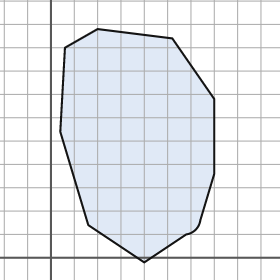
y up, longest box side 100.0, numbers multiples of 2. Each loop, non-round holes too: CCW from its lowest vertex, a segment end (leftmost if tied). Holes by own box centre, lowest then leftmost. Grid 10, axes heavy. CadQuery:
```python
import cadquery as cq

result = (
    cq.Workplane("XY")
    .moveTo(40.0, -2.0)
    .lineTo(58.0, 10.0)
    .threePointArc((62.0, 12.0), (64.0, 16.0))
    .lineTo(70.0, 36.0)
    .lineTo(70.0, 68.0)
    .lineTo(52.0, 94.0)
    .lineTo(20.0, 98.0)
    .lineTo(6.0, 90.0)
    .lineTo(4.0, 54.0)
    .lineTo(16.0, 14.0)
    .close()
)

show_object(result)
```